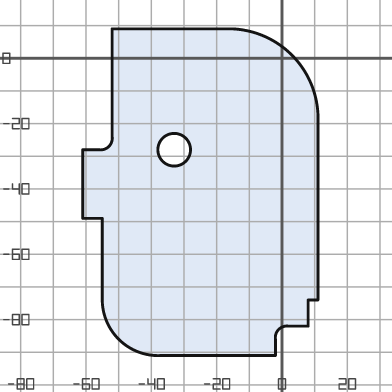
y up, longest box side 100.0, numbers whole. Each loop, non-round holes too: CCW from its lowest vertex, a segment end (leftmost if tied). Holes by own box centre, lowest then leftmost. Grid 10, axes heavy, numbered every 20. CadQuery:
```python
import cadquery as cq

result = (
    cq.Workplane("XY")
    .moveTo(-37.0, -91.0)
    .lineTo(-2.0, -91.0)
    .lineTo(-2.0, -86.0)
    .threePointArc((-1.0, -83.0), (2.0, -82.0))
    .lineTo(8.0, -82.0)
    .lineTo(8.0, -74.0)
    .lineTo(11.0, -74.0)
    .lineTo(11.0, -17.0)
    .threePointArc((3.0, 1.0), (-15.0, 9.0))
    .lineTo(-52.0, 9.0)
    .lineTo(-52.0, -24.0)
    .threePointArc((-53.0, -27.0), (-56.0, -28.0))
    .lineTo(-61.0, -28.0)
    .lineTo(-61.0, -49.0)
    .lineTo(-55.0, -49.0)
    .lineTo(-55.0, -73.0)
    .threePointArc((-50.0, -86.0), (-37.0, -91.0))
    .close()
    .moveTo(-33.0, -28.0)
    .circle(5.0)
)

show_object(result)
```